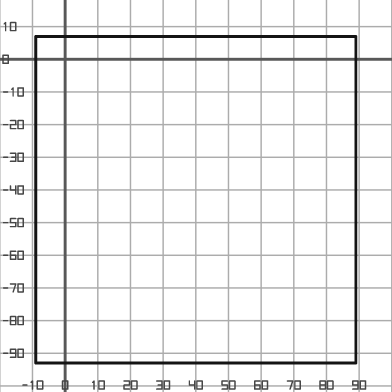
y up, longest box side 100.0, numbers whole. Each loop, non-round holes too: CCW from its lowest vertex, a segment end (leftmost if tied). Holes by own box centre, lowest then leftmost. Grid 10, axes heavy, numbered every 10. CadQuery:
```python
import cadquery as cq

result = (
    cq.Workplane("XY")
    .moveTo(-9.0, -93.0)
    .lineTo(89.0, -93.0)
    .lineTo(89.0, 7.0)
    .lineTo(-9.0, 7.0)
    .close()
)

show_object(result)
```